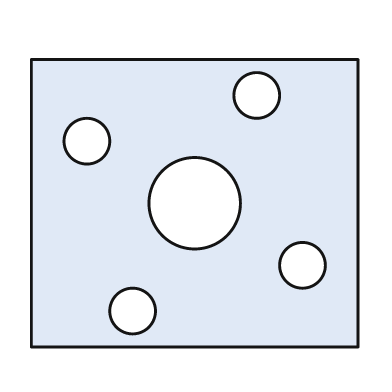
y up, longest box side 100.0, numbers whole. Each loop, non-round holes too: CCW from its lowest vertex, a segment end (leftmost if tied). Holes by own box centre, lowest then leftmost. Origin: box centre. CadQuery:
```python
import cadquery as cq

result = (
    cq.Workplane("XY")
    .moveTo(-50.0, -44.0)
    .lineTo(50.0, -44.0)
    .lineTo(50.0, 44.0)
    .lineTo(-50.0, 44.0)
    .close()
    .moveTo(-19.0, -33.0)
    .circle(7.0)
    .moveTo(33.0, -19.0)
    .circle(7.0)
    .moveTo(0.0, 0.0)
    .circle(14.0)
    .moveTo(-33.0, 19.0)
    .circle(7.0)
    .moveTo(19.0, 33.0)
    .circle(7.0)
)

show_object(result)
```